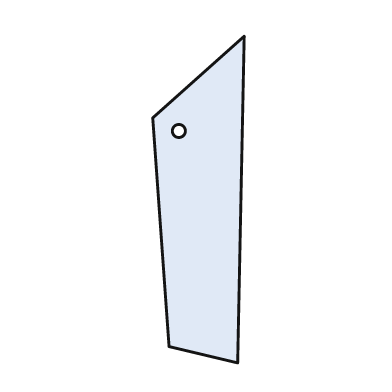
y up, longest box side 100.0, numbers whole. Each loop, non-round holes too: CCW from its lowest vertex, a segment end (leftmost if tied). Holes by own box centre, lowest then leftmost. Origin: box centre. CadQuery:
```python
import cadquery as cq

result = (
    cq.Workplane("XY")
    .moveTo(12.0, -50.0)
    .lineTo(14.0, 50.0)
    .lineTo(-14.0, 25.0)
    .lineTo(-9.0, -45.0)
    .close()
    .moveTo(-6.0, 21.0)
    .circle(2.0)
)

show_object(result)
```